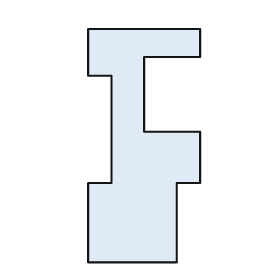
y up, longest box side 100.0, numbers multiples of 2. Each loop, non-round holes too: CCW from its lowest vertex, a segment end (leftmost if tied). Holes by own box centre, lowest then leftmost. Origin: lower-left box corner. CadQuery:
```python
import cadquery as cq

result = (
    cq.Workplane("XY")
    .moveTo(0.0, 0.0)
    .lineTo(38.0, 0.0)
    .lineTo(38.0, 34.0)
    .lineTo(48.0, 34.0)
    .lineTo(48.0, 56.0)
    .lineTo(24.0, 56.0)
    .lineTo(24.0, 88.0)
    .lineTo(48.0, 88.0)
    .lineTo(48.0, 100.0)
    .lineTo(0.0, 100.0)
    .lineTo(0.0, 80.0)
    .lineTo(10.0, 80.0)
    .lineTo(10.0, 34.0)
    .lineTo(0.0, 34.0)
    .close()
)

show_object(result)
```